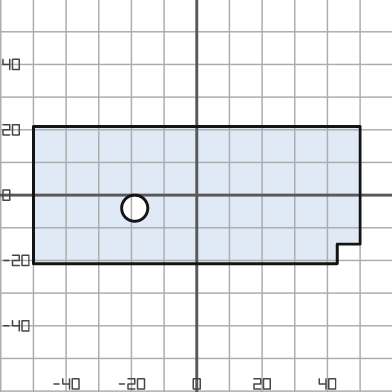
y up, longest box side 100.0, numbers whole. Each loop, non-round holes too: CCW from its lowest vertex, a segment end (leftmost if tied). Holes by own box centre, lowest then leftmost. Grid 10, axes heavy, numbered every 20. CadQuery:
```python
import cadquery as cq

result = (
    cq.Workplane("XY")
    .moveTo(-50.0, -21.0)
    .lineTo(43.0, -21.0)
    .lineTo(43.0, -15.0)
    .lineTo(50.0, -15.0)
    .lineTo(50.0, 21.0)
    .lineTo(-50.0, 21.0)
    .close()
    .moveTo(-19.0, -4.0)
    .circle(4.0)
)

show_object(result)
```